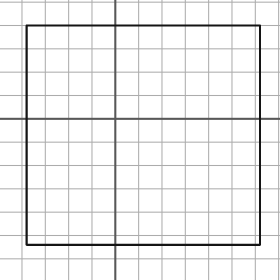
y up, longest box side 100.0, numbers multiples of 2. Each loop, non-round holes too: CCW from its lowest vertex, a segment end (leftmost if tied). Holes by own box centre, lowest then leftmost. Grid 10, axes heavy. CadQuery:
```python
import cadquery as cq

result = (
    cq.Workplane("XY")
    .moveTo(-38.0, -54.0)
    .lineTo(62.0, -54.0)
    .lineTo(62.0, 40.0)
    .lineTo(-38.0, 40.0)
    .close()
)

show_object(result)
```